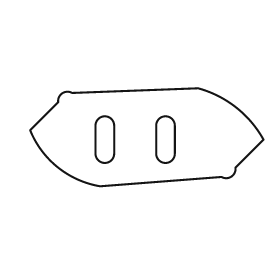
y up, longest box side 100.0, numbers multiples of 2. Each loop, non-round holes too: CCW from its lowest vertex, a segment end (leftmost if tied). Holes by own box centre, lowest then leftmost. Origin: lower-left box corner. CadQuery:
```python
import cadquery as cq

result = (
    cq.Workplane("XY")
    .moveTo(30.0, 0.0)
    .lineTo(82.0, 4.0)
    .threePointArc((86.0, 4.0), (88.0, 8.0))
    .lineTo(100.0, 20.0)
    .threePointArc((88.0, 34.0), (72.0, 42.0))
    .lineTo(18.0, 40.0)
    .threePointArc((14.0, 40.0), (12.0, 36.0))
    .lineTo(0.0, 24.0)
    .threePointArc((12.0, 8.0), (30.0, 0.0))
    .close()
    .moveTo(28.0, 14.0)
    .threePointArc((32.0, 10.0), (36.0, 14.0))
    .lineTo(36.0, 26.0)
    .threePointArc((32.0, 30.0), (28.0, 26.0))
    .close()
    .moveTo(54.0, 14.0)
    .threePointArc((58.0, 10.0), (62.0, 14.0))
    .lineTo(62.0, 26.0)
    .threePointArc((58.0, 30.0), (54.0, 26.0))
    .close()
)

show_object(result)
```